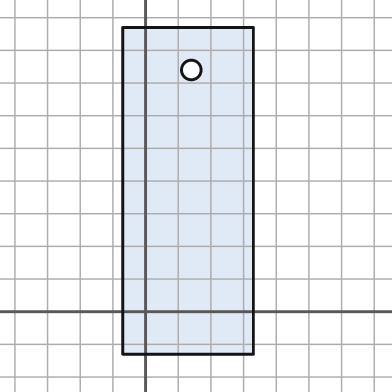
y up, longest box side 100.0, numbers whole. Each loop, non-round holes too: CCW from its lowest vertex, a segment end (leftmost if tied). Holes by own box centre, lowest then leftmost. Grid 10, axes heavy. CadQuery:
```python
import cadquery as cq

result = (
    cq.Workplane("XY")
    .moveTo(-7.0, -13.0)
    .lineTo(33.0, -13.0)
    .lineTo(33.0, 87.0)
    .lineTo(-7.0, 87.0)
    .close()
    .moveTo(14.0, 74.0)
    .circle(3.0)
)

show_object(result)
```